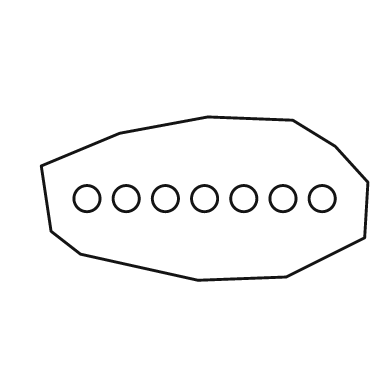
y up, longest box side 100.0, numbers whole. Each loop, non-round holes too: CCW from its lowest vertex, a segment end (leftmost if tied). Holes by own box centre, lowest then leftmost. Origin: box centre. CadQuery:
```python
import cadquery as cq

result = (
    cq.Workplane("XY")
    .moveTo(-2.0, -25.0)
    .lineTo(25.0, -24.0)
    .lineTo(49.0, -12.0)
    .lineTo(50.0, 5.0)
    .lineTo(40.0, 16.0)
    .lineTo(27.0, 24.0)
    .lineTo(1.0, 25.0)
    .lineTo(-26.0, 20.0)
    .lineTo(-50.0, 10.0)
    .lineTo(-47.0, -10.0)
    .lineTo(-38.0, -17.0)
    .close()
    .moveTo(-36.0, 0.0)
    .circle(4.0)
    .moveTo(-24.0, 0.0)
    .circle(4.0)
    .moveTo(-12.0, 0.0)
    .circle(4.0)
    .moveTo(0.0, 0.0)
    .circle(4.0)
    .moveTo(12.0, 0.0)
    .circle(4.0)
    .moveTo(24.0, 0.0)
    .circle(4.0)
    .moveTo(36.0, 0.0)
    .circle(4.0)
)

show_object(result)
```